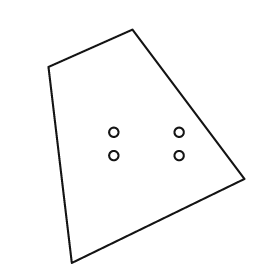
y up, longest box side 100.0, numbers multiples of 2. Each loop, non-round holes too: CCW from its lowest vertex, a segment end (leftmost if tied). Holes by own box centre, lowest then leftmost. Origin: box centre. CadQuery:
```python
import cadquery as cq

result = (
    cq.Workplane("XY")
    .moveTo(-32.0, -50.0)
    .lineTo(42.0, -14.0)
    .lineTo(-6.0, 50.0)
    .lineTo(-42.0, 34.0)
    .close()
    .moveTo(-14.0, -4.0)
    .circle(2.0)
    .moveTo(14.0, -4.0)
    .circle(2.0)
    .moveTo(-14.0, 6.0)
    .circle(2.0)
    .moveTo(14.0, 6.0)
    .circle(2.0)
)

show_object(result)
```